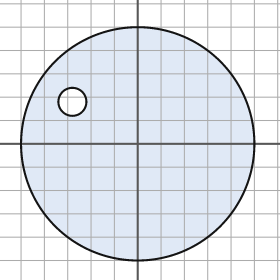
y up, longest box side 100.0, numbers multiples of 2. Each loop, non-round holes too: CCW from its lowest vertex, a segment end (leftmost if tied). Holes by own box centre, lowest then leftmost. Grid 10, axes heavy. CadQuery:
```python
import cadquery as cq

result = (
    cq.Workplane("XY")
    .moveTo(0.0, 0.0)
    .circle(50.0)
    .moveTo(-28.0, 18.0)
    .circle(6.0)
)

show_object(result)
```